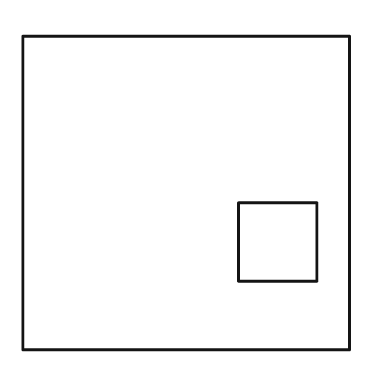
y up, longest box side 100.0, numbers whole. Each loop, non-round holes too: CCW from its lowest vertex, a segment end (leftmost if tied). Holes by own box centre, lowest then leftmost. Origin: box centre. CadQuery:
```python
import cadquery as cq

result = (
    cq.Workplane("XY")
    .moveTo(-50.0, -48.0)
    .lineTo(50.0, -48.0)
    .lineTo(50.0, 48.0)
    .lineTo(-50.0, 48.0)
    .close()
    .moveTo(16.0, -27.0)
    .lineTo(40.0, -27.0)
    .lineTo(40.0, -3.0)
    .lineTo(16.0, -3.0)
    .close()
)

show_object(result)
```